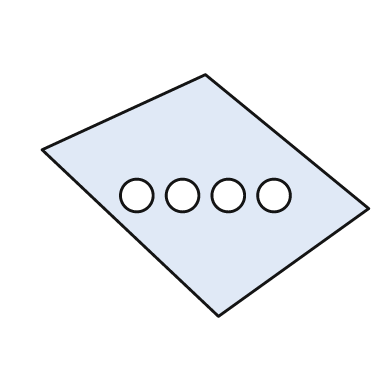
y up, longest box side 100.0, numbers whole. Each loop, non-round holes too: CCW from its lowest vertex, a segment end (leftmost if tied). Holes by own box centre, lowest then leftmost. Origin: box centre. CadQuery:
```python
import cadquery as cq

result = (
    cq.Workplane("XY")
    .moveTo(4.0, -37.0)
    .lineTo(50.0, -4.0)
    .lineTo(0.0, 37.0)
    .lineTo(-50.0, 14.0)
    .close()
    .moveTo(-21.0, 0.0)
    .circle(5.0)
    .moveTo(-7.0, 0.0)
    .circle(5.0)
    .moveTo(7.0, 0.0)
    .circle(5.0)
    .moveTo(21.0, 0.0)
    .circle(5.0)
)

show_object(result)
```